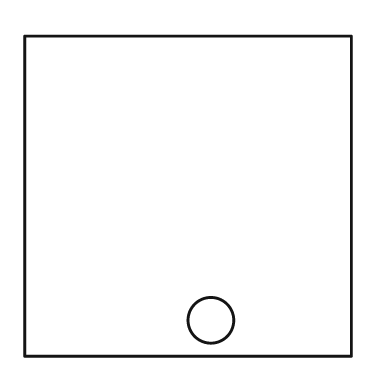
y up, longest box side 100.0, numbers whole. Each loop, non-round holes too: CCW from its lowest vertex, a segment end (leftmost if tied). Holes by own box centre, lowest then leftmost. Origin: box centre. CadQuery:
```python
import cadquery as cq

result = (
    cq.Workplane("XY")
    .moveTo(-50.0, -49.0)
    .lineTo(50.0, -49.0)
    .lineTo(50.0, 49.0)
    .lineTo(-50.0, 49.0)
    .close()
    .moveTo(7.0, -38.0)
    .circle(7.0)
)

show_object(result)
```